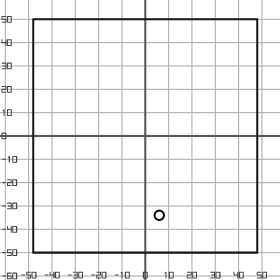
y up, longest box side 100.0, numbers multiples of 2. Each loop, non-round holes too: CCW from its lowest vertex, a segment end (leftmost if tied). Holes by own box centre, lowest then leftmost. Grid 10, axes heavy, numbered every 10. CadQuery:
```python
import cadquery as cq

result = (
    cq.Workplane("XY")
    .moveTo(-48.0, -50.0)
    .lineTo(48.0, -50.0)
    .lineTo(48.0, 50.0)
    .lineTo(-48.0, 50.0)
    .close()
    .moveTo(6.0, -34.0)
    .circle(2.0)
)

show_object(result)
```